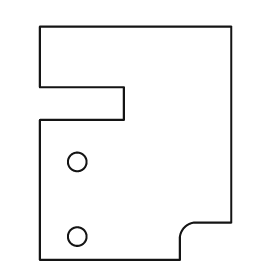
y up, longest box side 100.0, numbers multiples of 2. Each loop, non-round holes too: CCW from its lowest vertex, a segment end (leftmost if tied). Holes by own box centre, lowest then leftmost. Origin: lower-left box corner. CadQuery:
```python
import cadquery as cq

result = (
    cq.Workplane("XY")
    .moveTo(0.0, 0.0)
    .lineTo(60.0, 0.0)
    .lineTo(60.0, 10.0)
    .threePointArc((62.0, 14.0), (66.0, 16.0))
    .lineTo(82.0, 16.0)
    .lineTo(82.0, 100.0)
    .lineTo(0.0, 100.0)
    .lineTo(0.0, 74.0)
    .lineTo(36.0, 74.0)
    .lineTo(36.0, 60.0)
    .lineTo(0.0, 60.0)
    .close()
    .moveTo(16.0, 10.0)
    .circle(4.0)
    .moveTo(16.0, 42.0)
    .circle(4.0)
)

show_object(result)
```